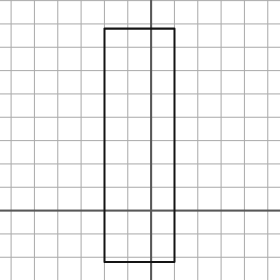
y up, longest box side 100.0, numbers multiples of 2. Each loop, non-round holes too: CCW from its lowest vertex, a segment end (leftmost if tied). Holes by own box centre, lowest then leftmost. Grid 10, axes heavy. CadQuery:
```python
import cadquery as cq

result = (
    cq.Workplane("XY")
    .moveTo(-20.0, -22.0)
    .lineTo(10.0, -22.0)
    .lineTo(10.0, 78.0)
    .lineTo(-20.0, 78.0)
    .close()
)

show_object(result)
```